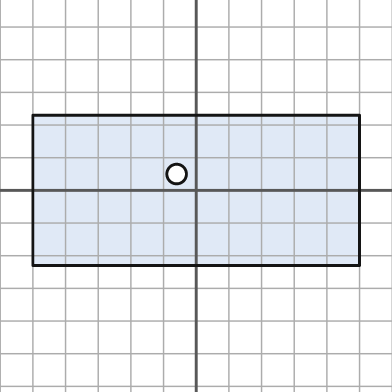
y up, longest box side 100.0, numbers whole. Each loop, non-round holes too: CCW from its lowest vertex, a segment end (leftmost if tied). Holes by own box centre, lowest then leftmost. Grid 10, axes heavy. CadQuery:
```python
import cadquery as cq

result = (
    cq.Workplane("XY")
    .moveTo(-50.0, -23.0)
    .lineTo(50.0, -23.0)
    .lineTo(50.0, 23.0)
    .lineTo(-50.0, 23.0)
    .close()
    .moveTo(-6.0, 5.0)
    .circle(3.0)
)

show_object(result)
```